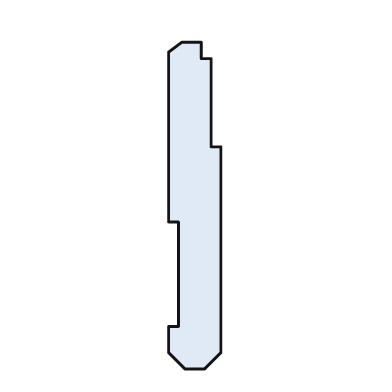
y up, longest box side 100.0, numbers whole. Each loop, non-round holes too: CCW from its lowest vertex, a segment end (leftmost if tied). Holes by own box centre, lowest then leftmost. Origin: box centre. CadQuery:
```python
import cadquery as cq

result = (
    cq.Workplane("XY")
    .moveTo(-3.0, -50.0)
    .lineTo(3.0, -50.0)
    .lineTo(8.0, -45.0)
    .lineTo(8.0, 18.0)
    .lineTo(5.0, 18.0)
    .lineTo(5.0, 45.0)
    .lineTo(2.0, 45.0)
    .lineTo(2.0, 50.0)
    .lineTo(-4.0, 50.0)
    .lineTo(-8.0, 47.0)
    .lineTo(-8.0, -5.0)
    .lineTo(-5.0, -5.0)
    .lineTo(-5.0, -37.0)
    .lineTo(-8.0, -37.0)
    .lineTo(-8.0, -45.0)
    .close()
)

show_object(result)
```